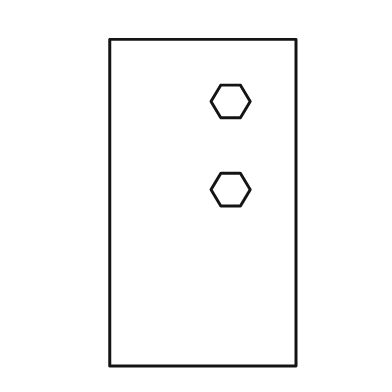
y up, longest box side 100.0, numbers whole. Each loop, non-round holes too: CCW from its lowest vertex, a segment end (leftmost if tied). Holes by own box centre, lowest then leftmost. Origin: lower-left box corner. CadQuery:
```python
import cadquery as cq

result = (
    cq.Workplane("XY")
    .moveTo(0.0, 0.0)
    .lineTo(57.0, 0.0)
    .lineTo(57.0, 100.0)
    .lineTo(0.0, 100.0)
    .close()
    .moveTo(34.0, 49.0)
    .lineTo(40.0, 49.0)
    .lineTo(43.0, 54.0)
    .lineTo(40.0, 59.0)
    .lineTo(34.0, 59.0)
    .lineTo(31.0, 54.0)
    .close()
    .moveTo(34.0, 76.0)
    .lineTo(40.0, 76.0)
    .lineTo(43.0, 81.0)
    .lineTo(40.0, 86.0)
    .lineTo(34.0, 86.0)
    .lineTo(31.0, 81.0)
    .close()
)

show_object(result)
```